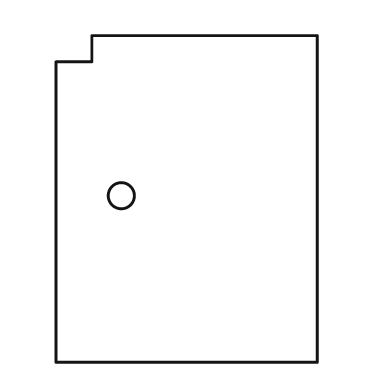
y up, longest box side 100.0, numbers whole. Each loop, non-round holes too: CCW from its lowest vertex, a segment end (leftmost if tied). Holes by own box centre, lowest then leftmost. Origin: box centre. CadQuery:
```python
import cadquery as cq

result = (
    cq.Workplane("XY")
    .moveTo(-40.0, -50.0)
    .lineTo(40.0, -50.0)
    .lineTo(40.0, 50.0)
    .lineTo(-29.0, 50.0)
    .lineTo(-29.0, 42.0)
    .lineTo(-40.0, 42.0)
    .close()
    .moveTo(-20.0, 1.0)
    .circle(4.0)
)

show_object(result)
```